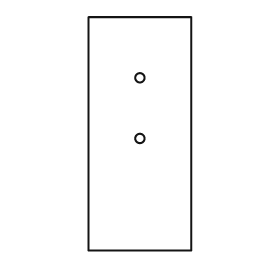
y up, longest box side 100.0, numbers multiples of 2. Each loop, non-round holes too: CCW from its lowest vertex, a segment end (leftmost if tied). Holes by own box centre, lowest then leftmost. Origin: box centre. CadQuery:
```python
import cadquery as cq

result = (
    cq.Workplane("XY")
    .moveTo(-22.0, -50.0)
    .lineTo(22.0, -50.0)
    .lineTo(22.0, 50.0)
    .lineTo(-22.0, 50.0)
    .close()
    .moveTo(0.0, -2.0)
    .circle(2.0)
    .moveTo(0.0, 24.0)
    .circle(2.0)
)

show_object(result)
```